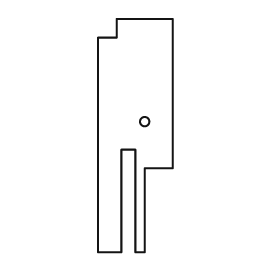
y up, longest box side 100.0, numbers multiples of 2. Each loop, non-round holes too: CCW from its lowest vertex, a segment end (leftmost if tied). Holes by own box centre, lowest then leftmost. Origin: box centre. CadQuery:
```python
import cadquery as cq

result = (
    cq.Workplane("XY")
    .moveTo(-16.0, -50.0)
    .lineTo(-6.0, -50.0)
    .lineTo(-6.0, -6.0)
    .lineTo(0.0, -6.0)
    .lineTo(0.0, -50.0)
    .lineTo(4.0, -50.0)
    .lineTo(4.0, -14.0)
    .lineTo(16.0, -14.0)
    .lineTo(16.0, 50.0)
    .lineTo(-8.0, 50.0)
    .lineTo(-8.0, 42.0)
    .lineTo(-16.0, 42.0)
    .close()
    .moveTo(4.0, 6.0)
    .circle(2.0)
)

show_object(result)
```